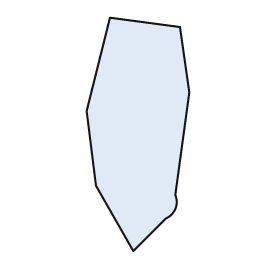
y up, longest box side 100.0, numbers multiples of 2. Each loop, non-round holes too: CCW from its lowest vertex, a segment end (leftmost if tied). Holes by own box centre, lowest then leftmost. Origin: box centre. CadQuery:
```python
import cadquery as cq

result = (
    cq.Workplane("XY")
    .moveTo(-2.0, -50.0)
    .lineTo(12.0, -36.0)
    .threePointArc((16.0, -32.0), (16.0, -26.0))
    .lineTo(22.0, 18.0)
    .lineTo(18.0, 46.0)
    .lineTo(-12.0, 50.0)
    .lineTo(-22.0, 10.0)
    .lineTo(-18.0, -22.0)
    .close()
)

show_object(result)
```